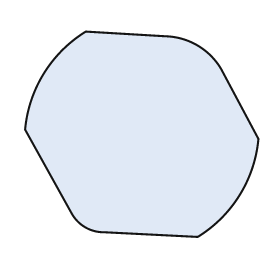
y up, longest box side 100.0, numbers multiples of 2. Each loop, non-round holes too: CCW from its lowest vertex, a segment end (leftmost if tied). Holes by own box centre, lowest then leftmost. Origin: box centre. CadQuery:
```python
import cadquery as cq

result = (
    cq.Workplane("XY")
    .moveTo(24.0, -44.0)
    .threePointArc((42.0, -26.0), (50.0, -2.0))
    .lineTo(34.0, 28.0)
    .threePointArc((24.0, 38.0), (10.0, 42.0))
    .lineTo(-24.0, 44.0)
    .threePointArc((-42.0, 26.0), (-50.0, 2.0))
    .lineTo(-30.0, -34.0)
    .threePointArc((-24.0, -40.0), (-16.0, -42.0))
    .close()
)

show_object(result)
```